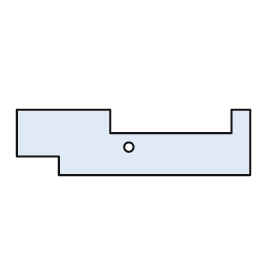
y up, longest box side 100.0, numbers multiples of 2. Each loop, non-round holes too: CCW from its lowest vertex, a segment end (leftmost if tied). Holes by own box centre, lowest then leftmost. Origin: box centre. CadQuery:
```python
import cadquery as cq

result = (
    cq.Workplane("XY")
    .moveTo(-32.0, -14.0)
    .lineTo(50.0, -14.0)
    .lineTo(50.0, 14.0)
    .lineTo(42.0, 14.0)
    .lineTo(42.0, 4.0)
    .lineTo(-10.0, 4.0)
    .lineTo(-10.0, 14.0)
    .lineTo(-50.0, 14.0)
    .lineTo(-50.0, -6.0)
    .lineTo(-32.0, -6.0)
    .close()
    .moveTo(-2.0, -2.0)
    .circle(2.0)
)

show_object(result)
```